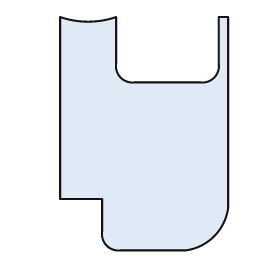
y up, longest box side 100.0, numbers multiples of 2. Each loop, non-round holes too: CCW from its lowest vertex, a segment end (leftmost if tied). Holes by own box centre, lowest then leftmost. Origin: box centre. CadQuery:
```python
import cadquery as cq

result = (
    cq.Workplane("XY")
    .moveTo(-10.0, -50.0)
    .lineTo(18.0, -50.0)
    .threePointArc((30.0, -44.0), (36.0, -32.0))
    .lineTo(36.0, 50.0)
    .lineTo(32.0, 50.0)
    .lineTo(32.0, 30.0)
    .threePointArc((30.0, 24.0), (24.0, 22.0))
    .lineTo(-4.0, 22.0)
    .threePointArc((-10.0, 24.0), (-12.0, 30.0))
    .lineTo(-12.0, 50.0)
    .threePointArc((-24.0, 48.0), (-36.0, 50.0))
    .lineTo(-36.0, -28.0)
    .lineTo(-18.0, -28.0)
    .lineTo(-18.0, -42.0)
    .threePointArc((-16.0, -48.0), (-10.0, -50.0))
    .close()
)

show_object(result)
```